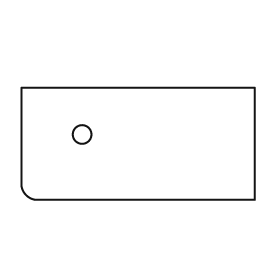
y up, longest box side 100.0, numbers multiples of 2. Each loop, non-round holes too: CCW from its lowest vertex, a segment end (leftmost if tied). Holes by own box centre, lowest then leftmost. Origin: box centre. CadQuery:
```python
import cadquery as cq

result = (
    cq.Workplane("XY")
    .moveTo(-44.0, -24.0)
    .lineTo(50.0, -24.0)
    .lineTo(50.0, 24.0)
    .lineTo(-50.0, 24.0)
    .lineTo(-50.0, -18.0)
    .threePointArc((-48.0, -22.0), (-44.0, -24.0))
    .close()
    .moveTo(-24.0, 4.0)
    .circle(4.0)
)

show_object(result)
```